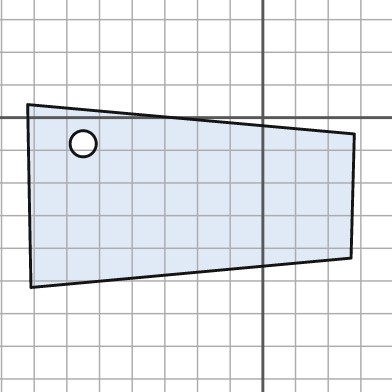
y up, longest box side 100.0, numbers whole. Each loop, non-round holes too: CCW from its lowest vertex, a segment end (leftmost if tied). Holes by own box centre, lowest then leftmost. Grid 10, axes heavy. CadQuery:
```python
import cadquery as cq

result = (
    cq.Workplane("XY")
    .moveTo(-71.0, -52.0)
    .lineTo(27.0, -43.0)
    .lineTo(28.0, -5.0)
    .lineTo(-72.0, 4.0)
    .close()
    .moveTo(-55.0, -8.0)
    .circle(4.0)
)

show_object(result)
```